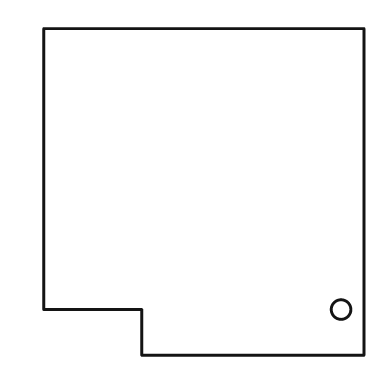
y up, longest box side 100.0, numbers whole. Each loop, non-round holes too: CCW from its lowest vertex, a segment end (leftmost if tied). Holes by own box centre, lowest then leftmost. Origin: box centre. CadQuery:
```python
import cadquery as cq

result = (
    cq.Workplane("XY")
    .moveTo(-19.0, -50.0)
    .lineTo(49.0, -50.0)
    .lineTo(49.0, 50.0)
    .lineTo(-49.0, 50.0)
    .lineTo(-49.0, -36.0)
    .lineTo(-19.0, -36.0)
    .close()
    .moveTo(42.0, -36.0)
    .circle(3.0)
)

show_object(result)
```